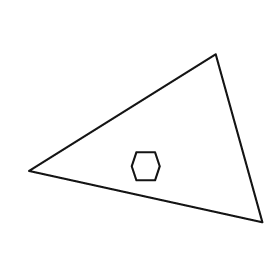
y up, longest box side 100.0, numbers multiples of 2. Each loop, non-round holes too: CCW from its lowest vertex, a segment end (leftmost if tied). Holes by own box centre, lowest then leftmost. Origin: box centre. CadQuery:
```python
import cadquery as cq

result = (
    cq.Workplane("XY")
    .moveTo(50.0, -36.0)
    .lineTo(30.0, 36.0)
    .lineTo(-50.0, -14.0)
    .close()
    .moveTo(-4.0, -18.0)
    .lineTo(4.0, -18.0)
    .lineTo(6.0, -12.0)
    .lineTo(4.0, -6.0)
    .lineTo(-4.0, -6.0)
    .lineTo(-6.0, -12.0)
    .close()
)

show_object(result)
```